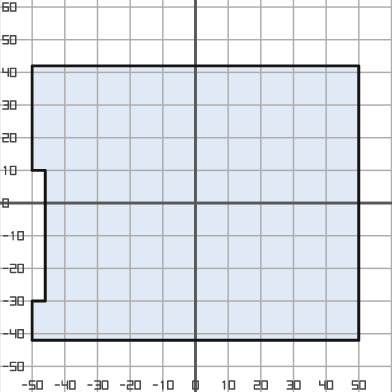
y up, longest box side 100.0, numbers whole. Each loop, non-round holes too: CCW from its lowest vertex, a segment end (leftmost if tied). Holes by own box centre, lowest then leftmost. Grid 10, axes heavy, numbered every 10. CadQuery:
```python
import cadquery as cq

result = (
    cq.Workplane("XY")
    .moveTo(-50.0, -42.0)
    .lineTo(50.0, -42.0)
    .lineTo(50.0, 42.0)
    .lineTo(-50.0, 42.0)
    .lineTo(-50.0, 10.0)
    .lineTo(-46.0, 10.0)
    .lineTo(-46.0, -30.0)
    .lineTo(-50.0, -30.0)
    .close()
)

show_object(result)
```